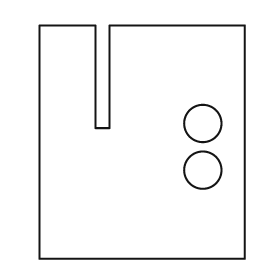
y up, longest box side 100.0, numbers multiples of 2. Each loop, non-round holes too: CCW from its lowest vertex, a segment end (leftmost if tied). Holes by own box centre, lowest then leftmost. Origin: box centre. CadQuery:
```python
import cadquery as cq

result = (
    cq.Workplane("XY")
    .moveTo(-44.0, -50.0)
    .lineTo(44.0, -50.0)
    .lineTo(44.0, 50.0)
    .lineTo(-14.0, 50.0)
    .lineTo(-14.0, 6.0)
    .lineTo(-20.0, 6.0)
    .lineTo(-20.0, 50.0)
    .lineTo(-44.0, 50.0)
    .close()
    .moveTo(26.0, -12.0)
    .circle(8.0)
    .moveTo(26.0, 8.0)
    .circle(8.0)
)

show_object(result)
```